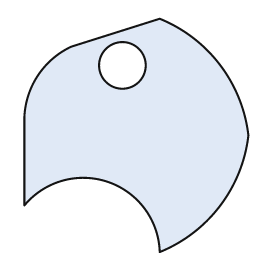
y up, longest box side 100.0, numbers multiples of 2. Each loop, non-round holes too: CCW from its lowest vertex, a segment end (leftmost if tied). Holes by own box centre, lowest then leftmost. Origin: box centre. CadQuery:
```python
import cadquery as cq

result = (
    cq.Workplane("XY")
    .moveTo(10.0, -50.0)
    .threePointArc((36.0, -30.0), (48.0, 0.0))
    .threePointArc((36.0, 30.0), (10.0, 50.0))
    .lineTo(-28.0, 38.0)
    .threePointArc((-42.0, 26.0), (-48.0, 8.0))
    .lineTo(-48.0, -30.0)
    .threePointArc((-12.0, -20.0), (10.0, -50.0))
    .close()
    .moveTo(-6.0, 30.0)
    .circle(10.0)
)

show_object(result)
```